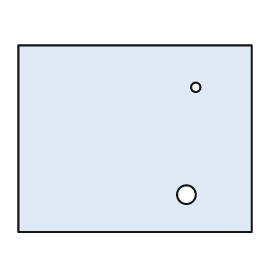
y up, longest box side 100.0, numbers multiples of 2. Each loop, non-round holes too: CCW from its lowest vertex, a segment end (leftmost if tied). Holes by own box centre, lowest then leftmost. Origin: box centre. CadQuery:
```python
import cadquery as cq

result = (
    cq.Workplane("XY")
    .moveTo(-50.0, -40.0)
    .lineTo(50.0, -40.0)
    .lineTo(50.0, 40.0)
    .lineTo(-50.0, 40.0)
    .close()
    .moveTo(22.0, -24.0)
    .circle(4.0)
    .moveTo(26.0, 22.0)
    .circle(2.0)
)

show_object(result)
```